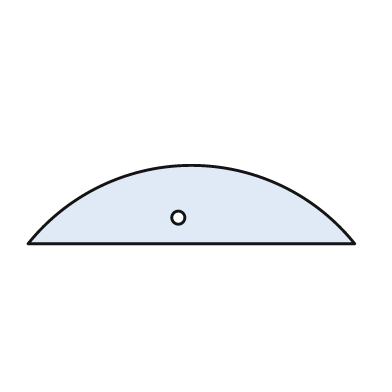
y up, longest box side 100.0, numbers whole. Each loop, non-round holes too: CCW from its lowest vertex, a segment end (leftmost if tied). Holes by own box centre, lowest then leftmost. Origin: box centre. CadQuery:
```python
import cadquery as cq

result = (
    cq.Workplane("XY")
    .moveTo(-50.0, -12.0)
    .lineTo(50.0, -12.0)
    .threePointArc((0.0, 12.0), (-50.0, -12.0))
    .close()
    .moveTo(-4.0, -4.0)
    .circle(2.0)
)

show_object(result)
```